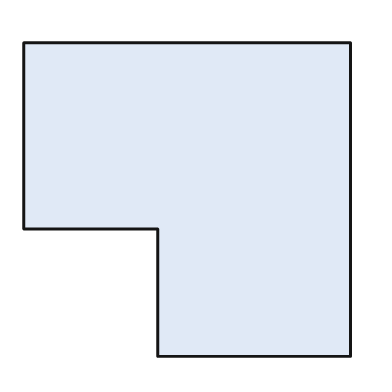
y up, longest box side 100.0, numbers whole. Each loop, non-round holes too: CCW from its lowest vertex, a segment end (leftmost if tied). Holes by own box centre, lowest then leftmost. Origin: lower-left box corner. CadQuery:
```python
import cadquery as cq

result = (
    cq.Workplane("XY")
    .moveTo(41.0, 0.0)
    .lineTo(100.0, 0.0)
    .lineTo(100.0, 96.0)
    .lineTo(0.0, 96.0)
    .lineTo(0.0, 39.0)
    .lineTo(41.0, 39.0)
    .close()
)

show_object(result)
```